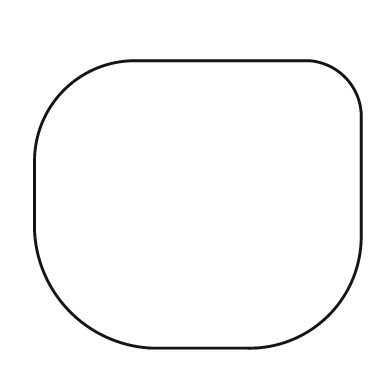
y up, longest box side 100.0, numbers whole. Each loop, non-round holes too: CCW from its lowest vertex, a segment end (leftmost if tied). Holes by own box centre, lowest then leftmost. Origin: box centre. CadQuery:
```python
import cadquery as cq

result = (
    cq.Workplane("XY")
    .moveTo(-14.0, -44.0)
    .lineTo(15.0, -44.0)
    .threePointArc((40.0, -34.0), (50.0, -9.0))
    .lineTo(50.0, 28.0)
    .threePointArc((45.0, 39.0), (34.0, 44.0))
    .lineTo(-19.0, 44.0)
    .threePointArc((-41.0, 35.0), (-50.0, 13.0))
    .lineTo(-50.0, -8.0)
    .threePointArc((-39.0, -33.0), (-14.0, -44.0))
    .close()
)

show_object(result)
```